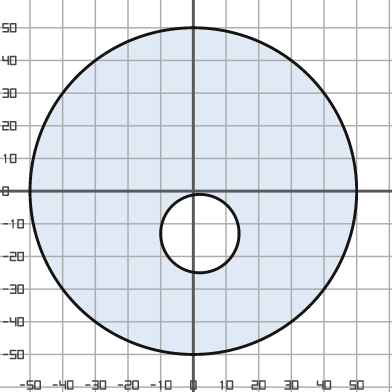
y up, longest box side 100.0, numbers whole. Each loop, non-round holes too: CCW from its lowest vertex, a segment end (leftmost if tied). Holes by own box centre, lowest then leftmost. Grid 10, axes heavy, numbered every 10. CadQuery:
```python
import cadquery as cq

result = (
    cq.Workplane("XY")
    .moveTo(0.0, 0.0)
    .circle(50.0)
    .moveTo(2.0, -13.0)
    .circle(12.0)
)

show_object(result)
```